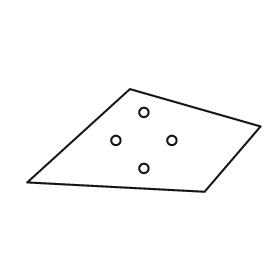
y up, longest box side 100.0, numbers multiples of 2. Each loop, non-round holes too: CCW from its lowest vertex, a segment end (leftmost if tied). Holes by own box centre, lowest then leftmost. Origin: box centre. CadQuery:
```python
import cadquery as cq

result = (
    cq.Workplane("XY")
    .moveTo(26.0, -22.0)
    .lineTo(50.0, 6.0)
    .lineTo(-6.0, 22.0)
    .lineTo(-50.0, -18.0)
    .close()
    .moveTo(0.0, -12.0)
    .circle(2.0)
    .moveTo(-12.0, 0.0)
    .circle(2.0)
    .moveTo(12.0, 0.0)
    .circle(2.0)
    .moveTo(0.0, 12.0)
    .circle(2.0)
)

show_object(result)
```